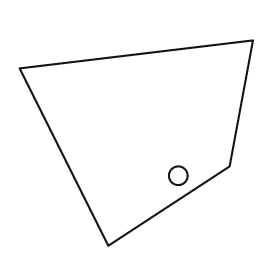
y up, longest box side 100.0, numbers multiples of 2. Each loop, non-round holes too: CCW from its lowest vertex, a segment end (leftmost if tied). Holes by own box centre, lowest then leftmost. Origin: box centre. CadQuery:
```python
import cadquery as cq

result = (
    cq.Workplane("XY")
    .moveTo(-12.0, -44.0)
    .lineTo(40.0, -10.0)
    .lineTo(50.0, 44.0)
    .lineTo(-50.0, 32.0)
    .close()
    .moveTo(18.0, -14.0)
    .circle(4.0)
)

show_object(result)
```